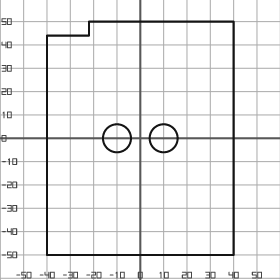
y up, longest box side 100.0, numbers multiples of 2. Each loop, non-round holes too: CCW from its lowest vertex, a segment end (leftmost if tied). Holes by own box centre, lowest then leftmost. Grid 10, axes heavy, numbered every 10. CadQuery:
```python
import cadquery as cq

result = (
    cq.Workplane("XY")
    .moveTo(-40.0, -50.0)
    .lineTo(40.0, -50.0)
    .lineTo(40.0, 50.0)
    .lineTo(-22.0, 50.0)
    .lineTo(-22.0, 44.0)
    .lineTo(-40.0, 44.0)
    .close()
    .moveTo(-10.0, 0.0)
    .circle(6.0)
    .moveTo(10.0, 0.0)
    .circle(6.0)
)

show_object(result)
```